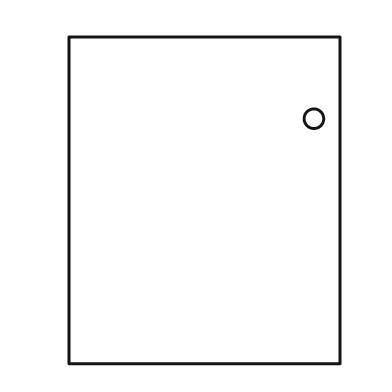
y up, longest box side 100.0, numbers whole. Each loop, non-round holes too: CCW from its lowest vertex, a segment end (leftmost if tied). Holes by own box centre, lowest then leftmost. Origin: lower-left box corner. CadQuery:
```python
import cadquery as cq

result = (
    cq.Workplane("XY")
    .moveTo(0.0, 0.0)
    .lineTo(83.0, 0.0)
    .lineTo(83.0, 100.0)
    .lineTo(0.0, 100.0)
    .close()
    .moveTo(75.0, 75.0)
    .circle(3.0)
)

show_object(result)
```